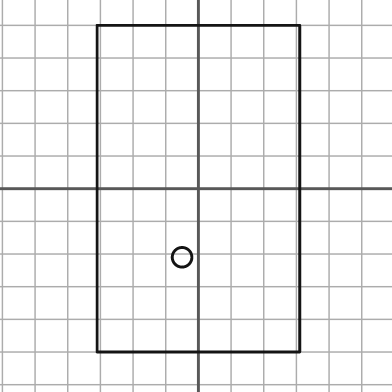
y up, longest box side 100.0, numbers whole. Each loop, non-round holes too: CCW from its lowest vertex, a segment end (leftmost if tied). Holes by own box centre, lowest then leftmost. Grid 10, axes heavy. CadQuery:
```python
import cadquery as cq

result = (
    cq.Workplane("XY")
    .moveTo(-31.0, -50.0)
    .lineTo(31.0, -50.0)
    .lineTo(31.0, 50.0)
    .lineTo(-31.0, 50.0)
    .close()
    .moveTo(-5.0, -21.0)
    .circle(3.0)
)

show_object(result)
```